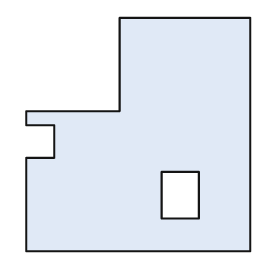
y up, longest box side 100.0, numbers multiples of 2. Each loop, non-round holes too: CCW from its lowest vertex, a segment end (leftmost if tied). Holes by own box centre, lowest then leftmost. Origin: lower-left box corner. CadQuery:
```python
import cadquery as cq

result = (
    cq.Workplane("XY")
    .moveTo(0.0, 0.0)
    .lineTo(96.0, 0.0)
    .lineTo(96.0, 100.0)
    .lineTo(40.0, 100.0)
    .lineTo(40.0, 60.0)
    .lineTo(0.0, 60.0)
    .lineTo(0.0, 54.0)
    .lineTo(12.0, 54.0)
    .lineTo(12.0, 40.0)
    .lineTo(0.0, 40.0)
    .close()
    .moveTo(58.0, 14.0)
    .lineTo(74.0, 14.0)
    .lineTo(74.0, 34.0)
    .lineTo(58.0, 34.0)
    .close()
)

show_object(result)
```